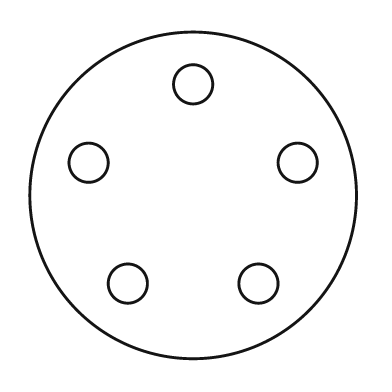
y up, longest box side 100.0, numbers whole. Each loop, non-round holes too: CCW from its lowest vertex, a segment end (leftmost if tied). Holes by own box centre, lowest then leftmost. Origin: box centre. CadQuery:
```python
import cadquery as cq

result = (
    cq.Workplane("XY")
    .moveTo(0.0, 0.0)
    .circle(50.0)
    .moveTo(-20.0, -27.0)
    .circle(6.0)
    .moveTo(20.0, -27.0)
    .circle(6.0)
    .moveTo(-32.0, 10.0)
    .circle(6.0)
    .moveTo(32.0, 10.0)
    .circle(6.0)
    .moveTo(0.0, 34.0)
    .circle(6.0)
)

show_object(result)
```